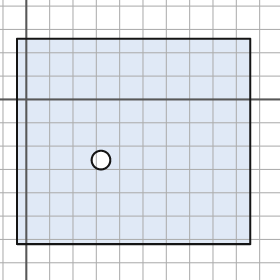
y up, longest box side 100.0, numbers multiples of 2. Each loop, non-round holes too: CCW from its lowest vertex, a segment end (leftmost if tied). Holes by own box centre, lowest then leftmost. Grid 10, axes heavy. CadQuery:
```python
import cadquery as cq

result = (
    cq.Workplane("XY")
    .moveTo(-4.0, -62.0)
    .lineTo(96.0, -62.0)
    .lineTo(96.0, 26.0)
    .lineTo(-4.0, 26.0)
    .close()
    .moveTo(32.0, -26.0)
    .circle(4.0)
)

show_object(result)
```